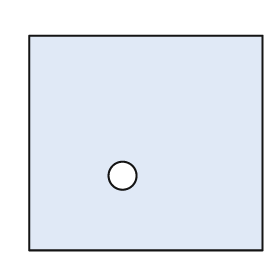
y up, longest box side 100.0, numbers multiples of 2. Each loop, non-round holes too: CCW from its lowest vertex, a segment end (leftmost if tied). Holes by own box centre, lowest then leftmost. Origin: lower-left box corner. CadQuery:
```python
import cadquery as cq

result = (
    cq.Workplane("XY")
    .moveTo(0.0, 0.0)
    .lineTo(100.0, 0.0)
    .lineTo(100.0, 92.0)
    .lineTo(0.0, 92.0)
    .close()
    .moveTo(40.0, 32.0)
    .circle(6.0)
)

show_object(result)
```